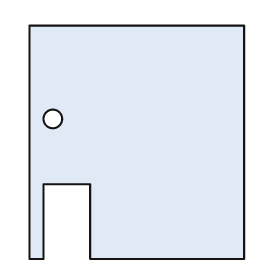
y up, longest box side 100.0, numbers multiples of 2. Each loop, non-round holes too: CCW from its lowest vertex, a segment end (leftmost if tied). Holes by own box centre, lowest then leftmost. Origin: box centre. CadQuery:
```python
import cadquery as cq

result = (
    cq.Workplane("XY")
    .moveTo(-46.0, -50.0)
    .lineTo(-40.0, -50.0)
    .lineTo(-40.0, -18.0)
    .lineTo(-20.0, -18.0)
    .lineTo(-20.0, -50.0)
    .lineTo(46.0, -50.0)
    .lineTo(46.0, 50.0)
    .lineTo(-46.0, 50.0)
    .close()
    .moveTo(-36.0, 10.0)
    .circle(4.0)
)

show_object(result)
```